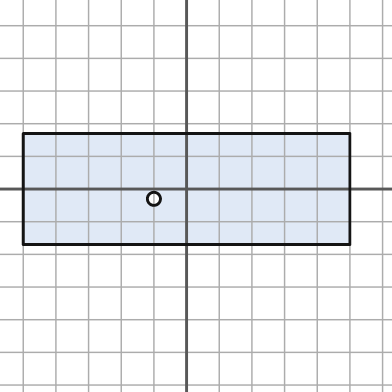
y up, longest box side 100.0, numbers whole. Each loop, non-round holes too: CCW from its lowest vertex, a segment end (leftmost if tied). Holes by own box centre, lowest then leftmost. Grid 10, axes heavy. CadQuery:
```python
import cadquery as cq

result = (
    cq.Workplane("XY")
    .moveTo(-50.0, -17.0)
    .lineTo(50.0, -17.0)
    .lineTo(50.0, 17.0)
    .lineTo(-50.0, 17.0)
    .close()
    .moveTo(-10.0, -3.0)
    .circle(2.0)
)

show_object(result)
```